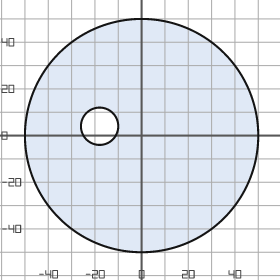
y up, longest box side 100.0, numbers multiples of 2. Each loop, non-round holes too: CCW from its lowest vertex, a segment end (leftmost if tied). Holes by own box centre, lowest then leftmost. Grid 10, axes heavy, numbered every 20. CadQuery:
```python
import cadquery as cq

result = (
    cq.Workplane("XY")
    .moveTo(0.0, 0.0)
    .circle(50.0)
    .moveTo(-18.0, 4.0)
    .circle(8.0)
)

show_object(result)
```